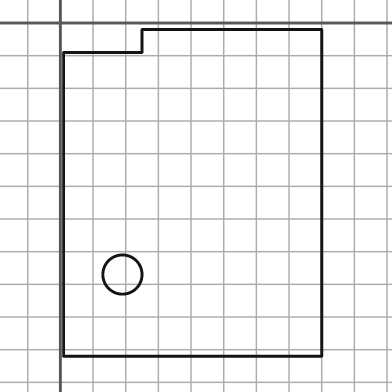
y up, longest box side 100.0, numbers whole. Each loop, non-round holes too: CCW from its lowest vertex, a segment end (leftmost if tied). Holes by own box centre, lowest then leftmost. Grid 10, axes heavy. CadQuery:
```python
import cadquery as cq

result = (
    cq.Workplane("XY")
    .moveTo(1.0, -102.0)
    .lineTo(80.0, -102.0)
    .lineTo(80.0, -2.0)
    .lineTo(25.0, -2.0)
    .lineTo(25.0, -9.0)
    .lineTo(1.0, -9.0)
    .close()
    .moveTo(19.0, -77.0)
    .circle(6.0)
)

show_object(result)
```